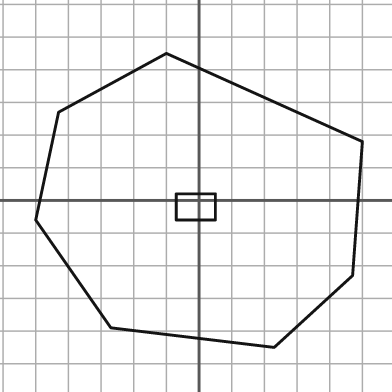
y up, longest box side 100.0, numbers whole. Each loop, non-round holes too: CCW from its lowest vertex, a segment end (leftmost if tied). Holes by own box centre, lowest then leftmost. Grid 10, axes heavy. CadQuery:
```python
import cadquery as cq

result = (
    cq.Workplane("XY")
    .moveTo(23.0, -45.0)
    .lineTo(47.0, -23.0)
    .lineTo(50.0, 18.0)
    .lineTo(-10.0, 45.0)
    .lineTo(-43.0, 27.0)
    .lineTo(-50.0, -6.0)
    .lineTo(-27.0, -39.0)
    .close()
    .moveTo(-7.0, -6.0)
    .lineTo(5.0, -6.0)
    .lineTo(5.0, 2.0)
    .lineTo(-7.0, 2.0)
    .close()
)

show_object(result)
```